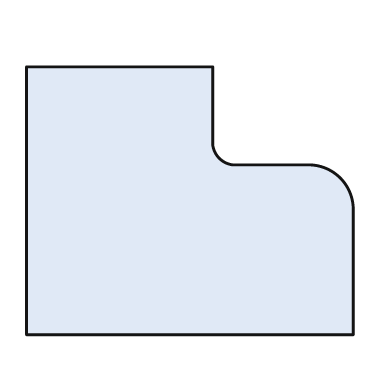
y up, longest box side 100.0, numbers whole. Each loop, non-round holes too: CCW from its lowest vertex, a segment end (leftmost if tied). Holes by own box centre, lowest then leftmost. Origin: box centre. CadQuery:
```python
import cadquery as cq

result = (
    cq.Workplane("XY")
    .moveTo(-50.0, -41.0)
    .lineTo(50.0, -41.0)
    .lineTo(50.0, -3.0)
    .threePointArc((46.0, 7.0), (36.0, 11.0))
    .lineTo(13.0, 11.0)
    .threePointArc((9.0, 13.0), (7.0, 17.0))
    .lineTo(7.0, 41.0)
    .lineTo(-50.0, 41.0)
    .close()
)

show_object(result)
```